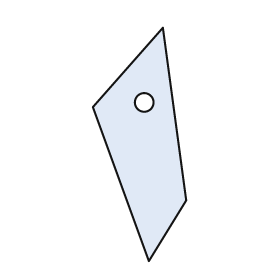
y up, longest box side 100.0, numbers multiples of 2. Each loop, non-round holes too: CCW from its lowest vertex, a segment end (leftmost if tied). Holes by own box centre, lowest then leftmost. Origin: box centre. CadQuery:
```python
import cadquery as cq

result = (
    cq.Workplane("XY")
    .moveTo(4.0, -50.0)
    .lineTo(20.0, -24.0)
    .lineTo(10.0, 50.0)
    .lineTo(-20.0, 16.0)
    .close()
    .moveTo(2.0, 18.0)
    .circle(4.0)
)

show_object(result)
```